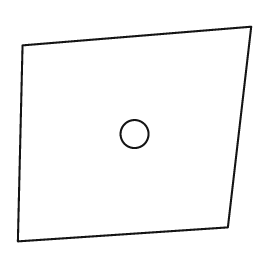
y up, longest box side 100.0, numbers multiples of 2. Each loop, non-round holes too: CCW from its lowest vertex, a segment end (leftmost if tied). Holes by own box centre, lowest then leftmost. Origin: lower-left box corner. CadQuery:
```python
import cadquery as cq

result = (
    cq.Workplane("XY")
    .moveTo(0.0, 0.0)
    .lineTo(90.0, 6.0)
    .lineTo(100.0, 92.0)
    .lineTo(2.0, 84.0)
    .close()
    .moveTo(50.0, 46.0)
    .circle(6.0)
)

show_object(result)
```